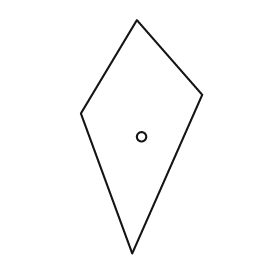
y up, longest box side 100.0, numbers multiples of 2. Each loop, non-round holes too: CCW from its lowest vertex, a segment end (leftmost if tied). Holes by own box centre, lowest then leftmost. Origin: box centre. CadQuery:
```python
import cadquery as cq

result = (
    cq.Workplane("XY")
    .moveTo(-4.0, -50.0)
    .lineTo(26.0, 18.0)
    .lineTo(-2.0, 50.0)
    .lineTo(-26.0, 10.0)
    .close()
    .moveTo(0.0, 0.0)
    .circle(2.0)
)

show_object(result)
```